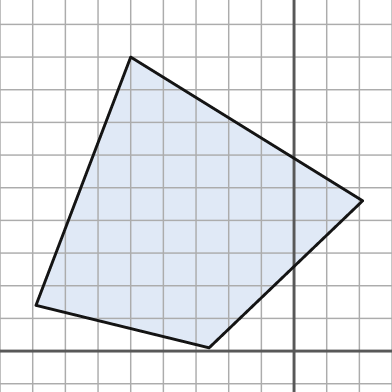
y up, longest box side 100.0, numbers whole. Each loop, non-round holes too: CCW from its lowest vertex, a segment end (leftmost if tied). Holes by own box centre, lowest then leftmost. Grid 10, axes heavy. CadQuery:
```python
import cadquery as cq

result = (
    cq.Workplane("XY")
    .moveTo(-26.0, 1.0)
    .lineTo(21.0, 46.0)
    .lineTo(-50.0, 90.0)
    .lineTo(-79.0, 14.0)
    .close()
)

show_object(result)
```